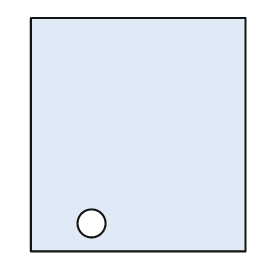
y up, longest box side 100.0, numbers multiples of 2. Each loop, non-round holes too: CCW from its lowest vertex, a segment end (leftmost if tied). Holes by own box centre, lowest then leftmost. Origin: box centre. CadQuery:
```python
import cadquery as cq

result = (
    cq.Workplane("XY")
    .moveTo(-46.0, -50.0)
    .lineTo(46.0, -50.0)
    .lineTo(46.0, 50.0)
    .lineTo(-46.0, 50.0)
    .close()
    .moveTo(-20.0, -38.0)
    .circle(6.0)
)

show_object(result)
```